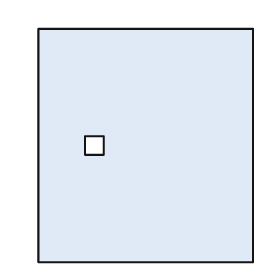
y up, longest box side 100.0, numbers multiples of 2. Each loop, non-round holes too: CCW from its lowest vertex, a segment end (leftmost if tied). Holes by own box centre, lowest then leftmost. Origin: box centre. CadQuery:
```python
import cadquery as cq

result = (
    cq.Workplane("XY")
    .moveTo(-46.0, -50.0)
    .lineTo(46.0, -50.0)
    .lineTo(46.0, 50.0)
    .lineTo(-46.0, 50.0)
    .close()
    .moveTo(-26.0, -4.0)
    .lineTo(-18.0, -4.0)
    .lineTo(-18.0, 4.0)
    .lineTo(-26.0, 4.0)
    .close()
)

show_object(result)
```